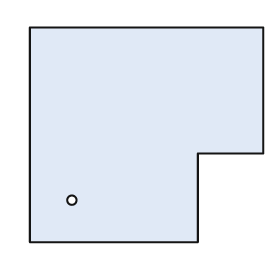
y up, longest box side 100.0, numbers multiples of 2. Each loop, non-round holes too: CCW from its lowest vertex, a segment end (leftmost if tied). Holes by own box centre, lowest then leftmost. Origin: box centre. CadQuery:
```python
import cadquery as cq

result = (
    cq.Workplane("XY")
    .moveTo(-50.0, -46.0)
    .lineTo(22.0, -46.0)
    .lineTo(22.0, -8.0)
    .lineTo(50.0, -8.0)
    .lineTo(50.0, 46.0)
    .lineTo(-50.0, 46.0)
    .close()
    .moveTo(-32.0, -28.0)
    .circle(2.0)
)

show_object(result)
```